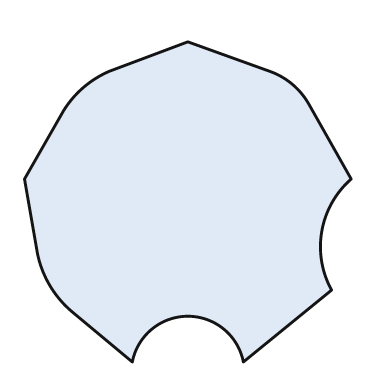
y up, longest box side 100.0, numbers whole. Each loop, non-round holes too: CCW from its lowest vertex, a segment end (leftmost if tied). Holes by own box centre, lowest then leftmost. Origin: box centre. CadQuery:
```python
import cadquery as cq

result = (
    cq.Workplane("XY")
    .moveTo(-17.0, -49.0)
    .threePointArc((0.0, -35.0), (17.0, -49.0))
    .lineTo(44.0, -27.0)
    .threePointArc((41.0, -9.0), (50.0, 7.0))
    .lineTo(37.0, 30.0)
    .threePointArc((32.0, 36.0), (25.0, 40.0))
    .lineTo(0.0, 49.0)
    .lineTo(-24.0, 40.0)
    .threePointArc((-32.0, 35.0), (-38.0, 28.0))
    .lineTo(-50.0, 7.0)
    .lineTo(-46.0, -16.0)
    .threePointArc((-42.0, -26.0), (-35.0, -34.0))
    .close()
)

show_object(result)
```